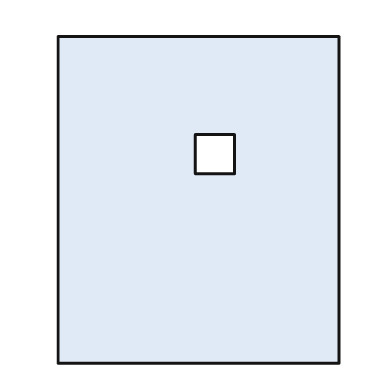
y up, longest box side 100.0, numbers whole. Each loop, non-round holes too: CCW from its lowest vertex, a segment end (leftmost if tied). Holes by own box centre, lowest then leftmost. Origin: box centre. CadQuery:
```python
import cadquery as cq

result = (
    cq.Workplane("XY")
    .moveTo(-43.0, -50.0)
    .lineTo(43.0, -50.0)
    .lineTo(43.0, 50.0)
    .lineTo(-43.0, 50.0)
    .close()
    .moveTo(-1.0, 8.0)
    .lineTo(11.0, 8.0)
    .lineTo(11.0, 20.0)
    .lineTo(-1.0, 20.0)
    .close()
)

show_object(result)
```